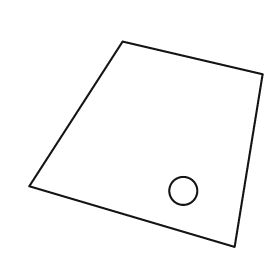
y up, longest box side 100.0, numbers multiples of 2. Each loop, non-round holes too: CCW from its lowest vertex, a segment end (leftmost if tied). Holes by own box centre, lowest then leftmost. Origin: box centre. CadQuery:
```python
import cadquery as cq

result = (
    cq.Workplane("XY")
    .moveTo(38.0, -44.0)
    .lineTo(50.0, 30.0)
    .lineTo(-10.0, 44.0)
    .lineTo(-50.0, -18.0)
    .close()
    .moveTo(16.0, -20.0)
    .circle(6.0)
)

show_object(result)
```